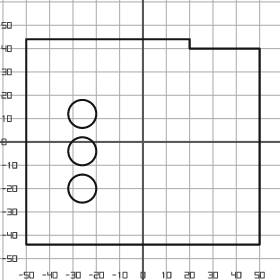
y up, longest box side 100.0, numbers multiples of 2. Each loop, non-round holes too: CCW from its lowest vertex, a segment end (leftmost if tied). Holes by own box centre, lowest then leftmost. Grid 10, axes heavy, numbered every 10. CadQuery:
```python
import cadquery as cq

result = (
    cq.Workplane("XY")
    .moveTo(-50.0, -44.0)
    .lineTo(50.0, -44.0)
    .lineTo(50.0, 40.0)
    .lineTo(20.0, 40.0)
    .lineTo(20.0, 44.0)
    .lineTo(-50.0, 44.0)
    .close()
    .moveTo(-26.0, -20.0)
    .circle(6.0)
    .moveTo(-26.0, -4.0)
    .circle(6.0)
    .moveTo(-26.0, 12.0)
    .circle(6.0)
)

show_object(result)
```